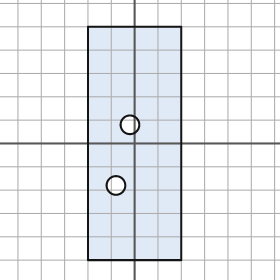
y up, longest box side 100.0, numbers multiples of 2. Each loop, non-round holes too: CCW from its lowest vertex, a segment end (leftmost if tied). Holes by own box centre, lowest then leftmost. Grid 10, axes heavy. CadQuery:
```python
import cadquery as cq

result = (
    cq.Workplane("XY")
    .moveTo(-20.0, -50.0)
    .lineTo(20.0, -50.0)
    .lineTo(20.0, 50.0)
    .lineTo(-20.0, 50.0)
    .close()
    .moveTo(-8.0, -18.0)
    .circle(4.0)
    .moveTo(-2.0, 8.0)
    .circle(4.0)
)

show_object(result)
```